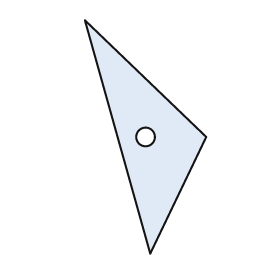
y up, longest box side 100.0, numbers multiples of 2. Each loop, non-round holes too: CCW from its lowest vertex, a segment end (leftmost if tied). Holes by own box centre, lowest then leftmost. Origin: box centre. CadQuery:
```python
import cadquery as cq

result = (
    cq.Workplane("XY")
    .moveTo(2.0, -50.0)
    .lineTo(26.0, 0.0)
    .lineTo(-26.0, 50.0)
    .close()
    .moveTo(0.0, 0.0)
    .circle(4.0)
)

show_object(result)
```